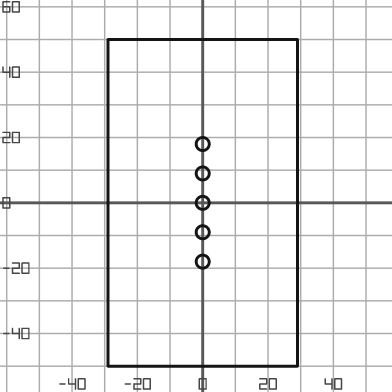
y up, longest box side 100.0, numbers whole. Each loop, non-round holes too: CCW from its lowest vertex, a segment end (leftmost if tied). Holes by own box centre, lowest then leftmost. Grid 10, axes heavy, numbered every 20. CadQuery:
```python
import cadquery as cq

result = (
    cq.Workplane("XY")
    .moveTo(-29.0, -50.0)
    .lineTo(29.0, -50.0)
    .lineTo(29.0, 50.0)
    .lineTo(-29.0, 50.0)
    .close()
    .moveTo(0.0, -18.0)
    .circle(2.0)
    .moveTo(0.0, -9.0)
    .circle(2.0)
    .moveTo(0.0, 0.0)
    .circle(2.0)
    .moveTo(0.0, 9.0)
    .circle(2.0)
    .moveTo(0.0, 18.0)
    .circle(2.0)
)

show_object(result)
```